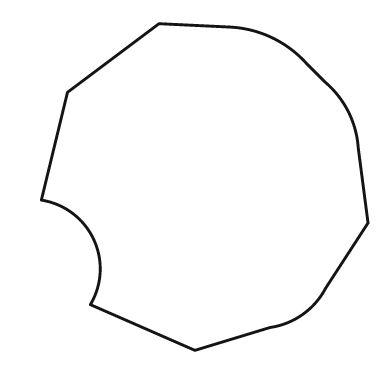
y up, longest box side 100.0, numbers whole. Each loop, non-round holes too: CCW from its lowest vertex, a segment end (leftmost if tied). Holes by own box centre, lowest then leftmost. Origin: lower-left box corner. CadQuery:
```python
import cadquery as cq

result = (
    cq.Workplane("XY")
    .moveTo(47.0, 0.0)
    .lineTo(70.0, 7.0)
    .threePointArc((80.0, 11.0), (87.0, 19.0))
    .lineTo(100.0, 39.0)
    .lineTo(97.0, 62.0)
    .threePointArc((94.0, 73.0), (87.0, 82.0))
    .lineTo(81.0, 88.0)
    .threePointArc((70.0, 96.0), (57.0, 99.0))
    .lineTo(36.0, 100.0)
    .lineTo(8.0, 79.0)
    .lineTo(0.0, 46.0)
    .threePointArc((16.0, 34.0), (15.0, 14.0))
    .close()
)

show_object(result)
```